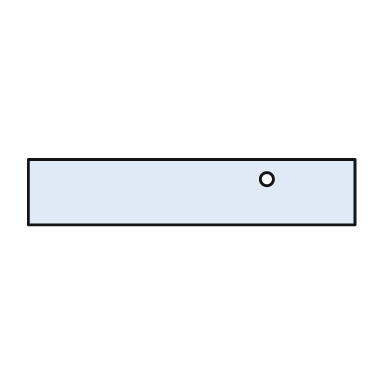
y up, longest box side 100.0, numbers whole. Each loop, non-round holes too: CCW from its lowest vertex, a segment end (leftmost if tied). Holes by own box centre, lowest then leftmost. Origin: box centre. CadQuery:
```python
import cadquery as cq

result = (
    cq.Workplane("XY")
    .moveTo(-50.0, -10.0)
    .lineTo(50.0, -10.0)
    .lineTo(50.0, 10.0)
    .lineTo(-50.0, 10.0)
    .close()
    .moveTo(23.0, 4.0)
    .circle(2.0)
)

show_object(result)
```